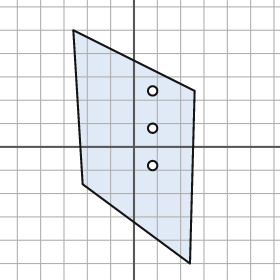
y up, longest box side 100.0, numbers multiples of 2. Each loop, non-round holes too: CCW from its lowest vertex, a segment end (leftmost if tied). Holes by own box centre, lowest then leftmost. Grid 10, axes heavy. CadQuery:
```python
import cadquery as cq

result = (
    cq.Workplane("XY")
    .moveTo(24.0, -50.0)
    .lineTo(26.0, 24.0)
    .lineTo(-26.0, 50.0)
    .lineTo(-22.0, -16.0)
    .close()
    .moveTo(8.0, -8.0)
    .circle(2.0)
    .moveTo(8.0, 8.0)
    .circle(2.0)
    .moveTo(8.0, 24.0)
    .circle(2.0)
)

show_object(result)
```